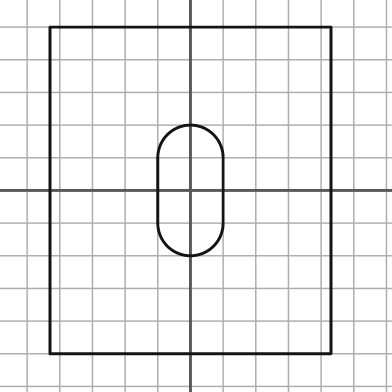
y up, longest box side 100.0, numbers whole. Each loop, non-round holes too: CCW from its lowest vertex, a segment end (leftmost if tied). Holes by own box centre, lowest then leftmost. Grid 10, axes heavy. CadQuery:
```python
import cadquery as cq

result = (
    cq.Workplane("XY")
    .moveTo(-43.0, -50.0)
    .lineTo(43.0, -50.0)
    .lineTo(43.0, 50.0)
    .lineTo(-43.0, 50.0)
    .close()
    .moveTo(-10.0, -10.0)
    .threePointArc((0.0, -20.0), (10.0, -10.0))
    .lineTo(10.0, 10.0)
    .threePointArc((0.0, 20.0), (-10.0, 10.0))
    .close()
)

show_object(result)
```